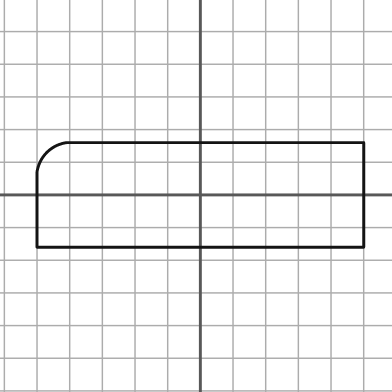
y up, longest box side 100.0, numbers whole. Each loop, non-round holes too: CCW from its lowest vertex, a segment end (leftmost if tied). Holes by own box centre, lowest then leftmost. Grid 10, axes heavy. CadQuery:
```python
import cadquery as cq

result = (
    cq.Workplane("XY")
    .moveTo(-50.0, -16.0)
    .lineTo(50.0, -16.0)
    .lineTo(50.0, 16.0)
    .lineTo(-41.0, 16.0)
    .threePointArc((-47.0, 13.0), (-50.0, 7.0))
    .close()
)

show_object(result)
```